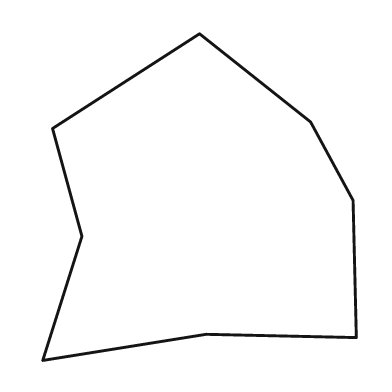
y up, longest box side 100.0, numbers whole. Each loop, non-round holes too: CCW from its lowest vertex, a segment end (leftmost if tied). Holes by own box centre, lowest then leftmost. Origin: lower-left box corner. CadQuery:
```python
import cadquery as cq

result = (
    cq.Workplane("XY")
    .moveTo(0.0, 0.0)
    .lineTo(50.0, 8.0)
    .lineTo(96.0, 7.0)
    .lineTo(95.0, 49.0)
    .lineTo(82.0, 73.0)
    .lineTo(48.0, 100.0)
    .lineTo(3.0, 71.0)
    .lineTo(12.0, 38.0)
    .close()
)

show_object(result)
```